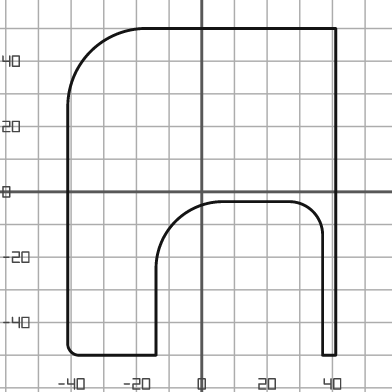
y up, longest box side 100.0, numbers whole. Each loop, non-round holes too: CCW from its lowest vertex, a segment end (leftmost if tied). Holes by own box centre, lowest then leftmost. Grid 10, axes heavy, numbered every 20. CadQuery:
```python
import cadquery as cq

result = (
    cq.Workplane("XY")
    .moveTo(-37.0, -50.0)
    .lineTo(-14.0, -50.0)
    .lineTo(-14.0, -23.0)
    .threePointArc((-8.0, -9.0), (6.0, -3.0))
    .lineTo(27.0, -3.0)
    .threePointArc((34.0, -6.0), (37.0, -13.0))
    .lineTo(37.0, -50.0)
    .lineTo(41.0, -50.0)
    .lineTo(41.0, 50.0)
    .lineTo(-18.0, 50.0)
    .threePointArc((-34.0, 43.0), (-41.0, 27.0))
    .lineTo(-41.0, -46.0)
    .threePointArc((-40.0, -49.0), (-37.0, -50.0))
    .close()
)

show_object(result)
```